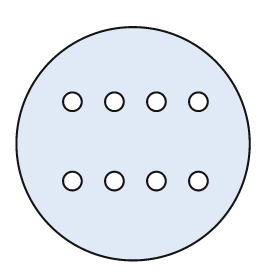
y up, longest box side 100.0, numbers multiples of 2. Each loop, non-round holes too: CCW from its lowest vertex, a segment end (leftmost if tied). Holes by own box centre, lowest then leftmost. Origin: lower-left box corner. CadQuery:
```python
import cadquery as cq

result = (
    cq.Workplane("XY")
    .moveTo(50.0, 50.0)
    .circle(50.0)
    .moveTo(24.0, 34.0)
    .circle(4.0)
    .moveTo(42.0, 34.0)
    .circle(4.0)
    .moveTo(60.0, 34.0)
    .circle(4.0)
    .moveTo(78.0, 34.0)
    .circle(4.0)
    .moveTo(24.0, 68.0)
    .circle(4.0)
    .moveTo(42.0, 68.0)
    .circle(4.0)
    .moveTo(60.0, 68.0)
    .circle(4.0)
    .moveTo(78.0, 68.0)
    .circle(4.0)
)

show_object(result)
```